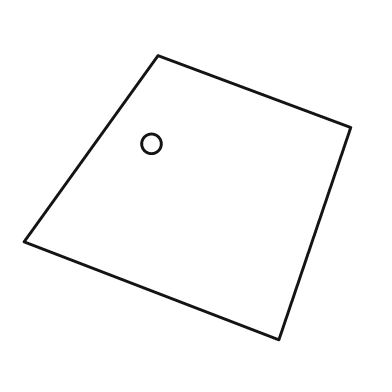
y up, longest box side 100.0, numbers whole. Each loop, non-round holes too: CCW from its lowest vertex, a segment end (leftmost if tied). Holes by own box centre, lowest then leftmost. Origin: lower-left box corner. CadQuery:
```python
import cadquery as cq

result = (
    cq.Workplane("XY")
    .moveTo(78.0, 0.0)
    .lineTo(100.0, 65.0)
    .lineTo(41.0, 87.0)
    .lineTo(0.0, 30.0)
    .close()
    .moveTo(39.0, 60.0)
    .circle(3.0)
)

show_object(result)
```